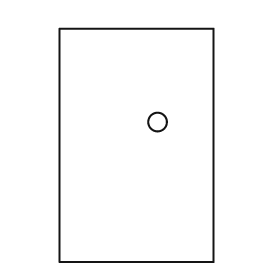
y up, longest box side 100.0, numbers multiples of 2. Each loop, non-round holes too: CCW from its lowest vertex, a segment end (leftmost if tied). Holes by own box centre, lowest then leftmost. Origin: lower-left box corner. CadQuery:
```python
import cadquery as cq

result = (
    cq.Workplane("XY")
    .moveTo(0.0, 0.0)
    .lineTo(66.0, 0.0)
    .lineTo(66.0, 100.0)
    .lineTo(0.0, 100.0)
    .close()
    .moveTo(42.0, 60.0)
    .circle(4.0)
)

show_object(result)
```